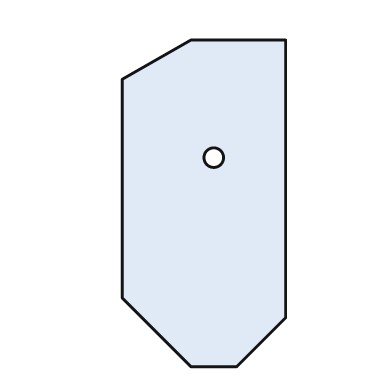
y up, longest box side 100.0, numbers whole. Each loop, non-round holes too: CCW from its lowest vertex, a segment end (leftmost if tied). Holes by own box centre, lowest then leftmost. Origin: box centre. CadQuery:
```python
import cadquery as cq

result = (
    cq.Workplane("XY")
    .moveTo(-4.0, -50.0)
    .lineTo(10.0, -50.0)
    .lineTo(25.0, -35.0)
    .lineTo(25.0, 50.0)
    .lineTo(-4.0, 50.0)
    .lineTo(-25.0, 38.0)
    .lineTo(-25.0, -29.0)
    .close()
    .moveTo(3.0, 14.0)
    .circle(3.0)
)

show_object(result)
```